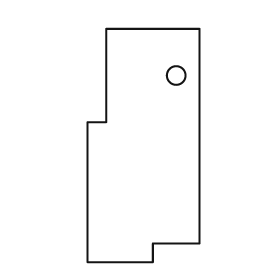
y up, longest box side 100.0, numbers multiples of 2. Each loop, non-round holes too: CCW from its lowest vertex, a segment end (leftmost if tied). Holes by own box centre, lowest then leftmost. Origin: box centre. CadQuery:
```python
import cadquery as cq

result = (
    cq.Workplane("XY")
    .moveTo(-24.0, -50.0)
    .lineTo(4.0, -50.0)
    .lineTo(4.0, -42.0)
    .lineTo(24.0, -42.0)
    .lineTo(24.0, 50.0)
    .lineTo(-16.0, 50.0)
    .lineTo(-16.0, 10.0)
    .lineTo(-24.0, 10.0)
    .close()
    .moveTo(14.0, 30.0)
    .circle(4.0)
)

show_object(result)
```